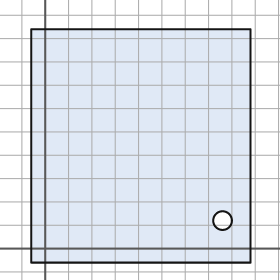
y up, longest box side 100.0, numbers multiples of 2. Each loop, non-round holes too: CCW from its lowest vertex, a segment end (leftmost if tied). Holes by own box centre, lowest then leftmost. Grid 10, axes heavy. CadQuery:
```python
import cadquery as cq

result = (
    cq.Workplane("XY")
    .moveTo(-6.0, -6.0)
    .lineTo(88.0, -6.0)
    .lineTo(88.0, 94.0)
    .lineTo(-6.0, 94.0)
    .close()
    .moveTo(76.0, 12.0)
    .circle(4.0)
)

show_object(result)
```